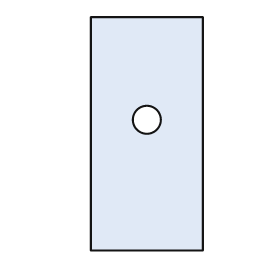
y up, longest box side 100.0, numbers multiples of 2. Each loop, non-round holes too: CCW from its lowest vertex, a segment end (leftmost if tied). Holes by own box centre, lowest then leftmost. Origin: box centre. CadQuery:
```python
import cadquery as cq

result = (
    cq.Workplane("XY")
    .moveTo(-24.0, -50.0)
    .lineTo(24.0, -50.0)
    .lineTo(24.0, 50.0)
    .lineTo(-24.0, 50.0)
    .close()
    .moveTo(0.0, 6.0)
    .circle(6.0)
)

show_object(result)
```